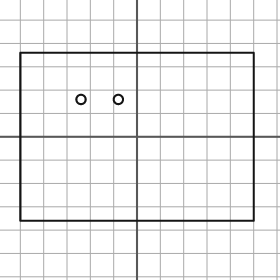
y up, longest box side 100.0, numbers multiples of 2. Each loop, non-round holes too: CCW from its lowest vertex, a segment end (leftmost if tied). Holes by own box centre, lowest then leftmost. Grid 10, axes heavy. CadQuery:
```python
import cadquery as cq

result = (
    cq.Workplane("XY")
    .moveTo(-50.0, -36.0)
    .lineTo(50.0, -36.0)
    .lineTo(50.0, 36.0)
    .lineTo(-50.0, 36.0)
    .close()
    .moveTo(-24.0, 16.0)
    .circle(2.0)
    .moveTo(-8.0, 16.0)
    .circle(2.0)
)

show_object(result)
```